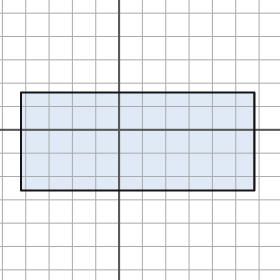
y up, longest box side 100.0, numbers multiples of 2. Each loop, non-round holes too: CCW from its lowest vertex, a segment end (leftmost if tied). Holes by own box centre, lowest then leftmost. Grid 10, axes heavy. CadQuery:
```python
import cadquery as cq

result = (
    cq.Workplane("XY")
    .moveTo(-42.0, -26.0)
    .lineTo(58.0, -26.0)
    .lineTo(58.0, 16.0)
    .lineTo(-42.0, 16.0)
    .close()
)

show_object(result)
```